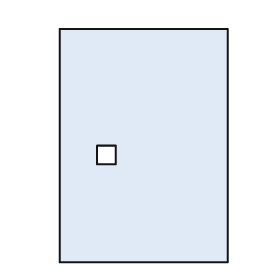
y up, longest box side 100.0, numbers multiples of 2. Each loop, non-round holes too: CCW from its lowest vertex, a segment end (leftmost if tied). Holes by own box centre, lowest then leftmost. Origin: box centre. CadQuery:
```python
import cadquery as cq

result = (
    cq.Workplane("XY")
    .moveTo(-36.0, -50.0)
    .lineTo(36.0, -50.0)
    .lineTo(36.0, 50.0)
    .lineTo(-36.0, 50.0)
    .close()
    .moveTo(-20.0, -8.0)
    .lineTo(-12.0, -8.0)
    .lineTo(-12.0, 0.0)
    .lineTo(-20.0, 0.0)
    .close()
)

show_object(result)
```